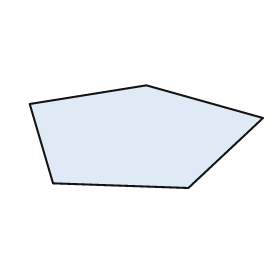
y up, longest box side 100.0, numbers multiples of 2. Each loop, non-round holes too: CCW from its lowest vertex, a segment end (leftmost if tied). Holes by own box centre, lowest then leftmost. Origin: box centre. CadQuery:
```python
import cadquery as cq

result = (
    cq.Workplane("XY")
    .moveTo(18.0, -22.0)
    .lineTo(50.0, 8.0)
    .lineTo(0.0, 22.0)
    .lineTo(-50.0, 14.0)
    .lineTo(-40.0, -20.0)
    .close()
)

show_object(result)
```